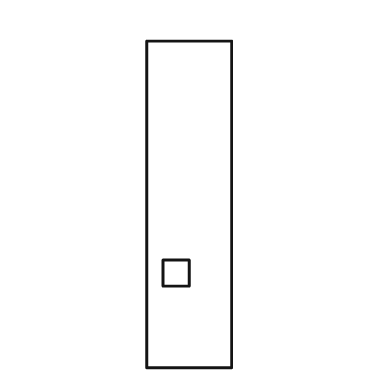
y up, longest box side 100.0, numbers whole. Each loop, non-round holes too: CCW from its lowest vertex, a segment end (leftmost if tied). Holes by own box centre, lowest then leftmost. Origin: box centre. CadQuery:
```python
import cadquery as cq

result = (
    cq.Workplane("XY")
    .moveTo(-13.0, -50.0)
    .lineTo(13.0, -50.0)
    .lineTo(13.0, 50.0)
    .lineTo(-13.0, 50.0)
    .close()
    .moveTo(-8.0, -25.0)
    .lineTo(0.0, -25.0)
    .lineTo(0.0, -17.0)
    .lineTo(-8.0, -17.0)
    .close()
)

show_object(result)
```